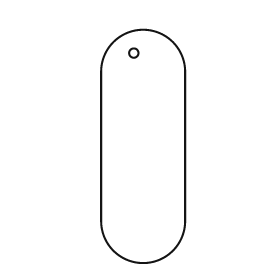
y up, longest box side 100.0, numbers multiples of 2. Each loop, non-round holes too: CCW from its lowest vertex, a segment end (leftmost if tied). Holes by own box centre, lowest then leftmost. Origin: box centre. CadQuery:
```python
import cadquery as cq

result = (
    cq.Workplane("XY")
    .moveTo(-18.0, -32.0)
    .threePointArc((0.0, -50.0), (18.0, -32.0))
    .lineTo(18.0, 32.0)
    .threePointArc((0.0, 50.0), (-18.0, 32.0))
    .close()
    .moveTo(-4.0, 40.0)
    .circle(2.0)
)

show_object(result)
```